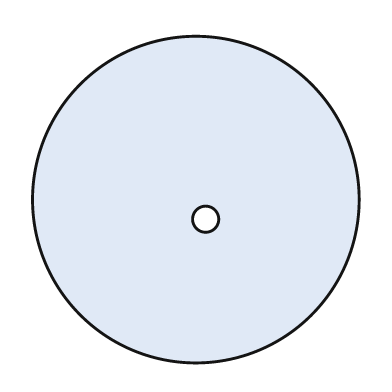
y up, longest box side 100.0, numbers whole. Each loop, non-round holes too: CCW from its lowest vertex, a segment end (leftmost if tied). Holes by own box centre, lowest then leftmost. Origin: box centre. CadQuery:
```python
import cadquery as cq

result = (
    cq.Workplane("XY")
    .moveTo(0.0, 0.0)
    .circle(50.0)
    .moveTo(3.0, -6.0)
    .circle(4.0)
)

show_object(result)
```